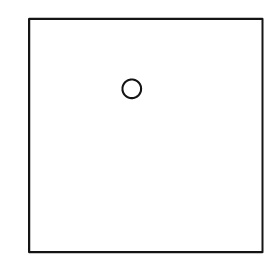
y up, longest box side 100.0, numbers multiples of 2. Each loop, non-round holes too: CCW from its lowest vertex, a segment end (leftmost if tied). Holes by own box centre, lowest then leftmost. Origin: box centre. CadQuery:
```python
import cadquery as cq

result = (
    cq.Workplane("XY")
    .moveTo(-50.0, -50.0)
    .lineTo(50.0, -50.0)
    .lineTo(50.0, 50.0)
    .lineTo(-50.0, 50.0)
    .close()
    .moveTo(-6.0, 20.0)
    .circle(4.0)
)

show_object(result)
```